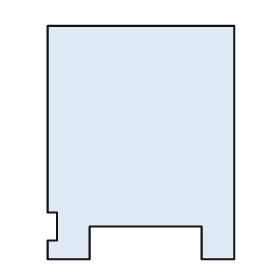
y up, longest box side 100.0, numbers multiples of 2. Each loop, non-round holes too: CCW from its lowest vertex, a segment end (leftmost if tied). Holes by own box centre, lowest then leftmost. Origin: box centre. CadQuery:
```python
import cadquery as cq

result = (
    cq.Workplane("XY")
    .moveTo(-40.0, -50.0)
    .lineTo(-22.0, -50.0)
    .lineTo(-22.0, -36.0)
    .lineTo(26.0, -36.0)
    .lineTo(26.0, -50.0)
    .lineTo(40.0, -50.0)
    .lineTo(40.0, 50.0)
    .lineTo(-40.0, 50.0)
    .lineTo(-40.0, -30.0)
    .lineTo(-36.0, -30.0)
    .lineTo(-36.0, -42.0)
    .lineTo(-40.0, -42.0)
    .close()
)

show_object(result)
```